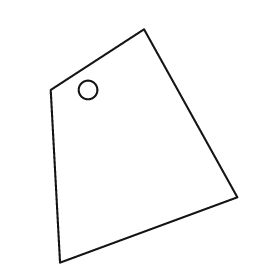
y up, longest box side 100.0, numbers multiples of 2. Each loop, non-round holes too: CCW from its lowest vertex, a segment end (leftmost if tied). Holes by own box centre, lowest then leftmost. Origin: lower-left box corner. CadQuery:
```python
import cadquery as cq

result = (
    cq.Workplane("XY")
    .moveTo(4.0, 0.0)
    .lineTo(80.0, 28.0)
    .lineTo(40.0, 100.0)
    .lineTo(0.0, 74.0)
    .close()
    .moveTo(16.0, 74.0)
    .circle(4.0)
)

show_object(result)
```